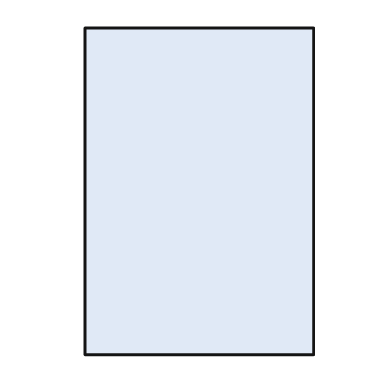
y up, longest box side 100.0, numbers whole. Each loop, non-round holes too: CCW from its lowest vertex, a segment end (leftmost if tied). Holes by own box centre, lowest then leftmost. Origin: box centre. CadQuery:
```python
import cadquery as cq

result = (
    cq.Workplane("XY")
    .moveTo(-35.0, -50.0)
    .lineTo(35.0, -50.0)
    .lineTo(35.0, 50.0)
    .lineTo(-35.0, 50.0)
    .close()
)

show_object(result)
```